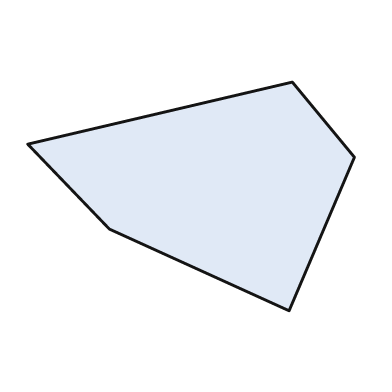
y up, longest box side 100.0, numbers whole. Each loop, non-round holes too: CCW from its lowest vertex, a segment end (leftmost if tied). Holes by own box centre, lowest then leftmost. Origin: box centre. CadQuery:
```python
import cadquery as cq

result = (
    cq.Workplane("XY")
    .moveTo(30.0, -35.0)
    .lineTo(50.0, 12.0)
    .lineTo(31.0, 35.0)
    .lineTo(-50.0, 16.0)
    .lineTo(-25.0, -10.0)
    .close()
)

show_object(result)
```